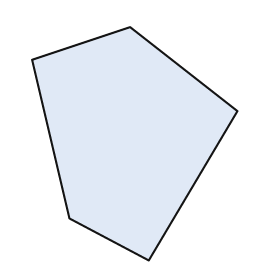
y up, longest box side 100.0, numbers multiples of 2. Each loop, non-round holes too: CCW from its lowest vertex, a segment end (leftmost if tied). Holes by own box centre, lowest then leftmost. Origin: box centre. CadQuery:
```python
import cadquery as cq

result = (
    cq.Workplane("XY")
    .moveTo(6.0, -50.0)
    .lineTo(44.0, 14.0)
    .lineTo(-2.0, 50.0)
    .lineTo(-44.0, 36.0)
    .lineTo(-28.0, -32.0)
    .close()
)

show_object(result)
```